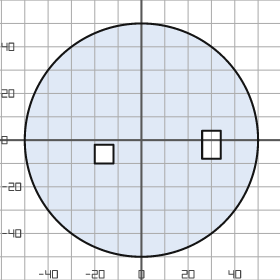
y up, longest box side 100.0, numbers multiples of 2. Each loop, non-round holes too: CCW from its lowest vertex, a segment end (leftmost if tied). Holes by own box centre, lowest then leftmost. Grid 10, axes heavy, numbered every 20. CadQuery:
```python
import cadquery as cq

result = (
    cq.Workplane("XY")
    .moveTo(0.0, 0.0)
    .circle(50.0)
    .moveTo(-20.0, -10.0)
    .lineTo(-12.0, -10.0)
    .lineTo(-12.0, -2.0)
    .lineTo(-20.0, -2.0)
    .close()
    .moveTo(26.0, -8.0)
    .lineTo(34.0, -8.0)
    .lineTo(34.0, 4.0)
    .lineTo(26.0, 4.0)
    .close()
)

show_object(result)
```